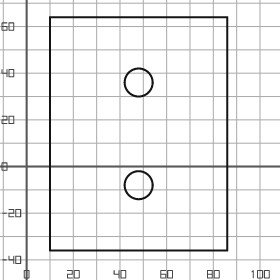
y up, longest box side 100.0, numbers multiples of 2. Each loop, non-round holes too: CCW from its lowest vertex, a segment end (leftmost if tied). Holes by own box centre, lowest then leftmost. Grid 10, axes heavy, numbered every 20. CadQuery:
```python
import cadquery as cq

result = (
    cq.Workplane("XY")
    .moveTo(10.0, -36.0)
    .lineTo(86.0, -36.0)
    .lineTo(86.0, 64.0)
    .lineTo(10.0, 64.0)
    .close()
    .moveTo(48.0, -8.0)
    .circle(6.0)
    .moveTo(48.0, 36.0)
    .circle(6.0)
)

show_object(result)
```